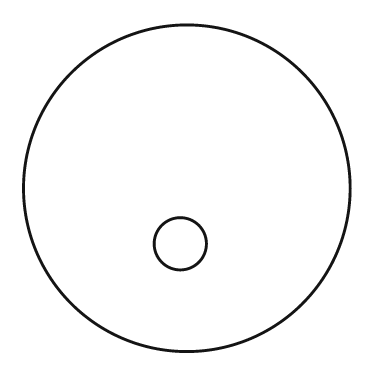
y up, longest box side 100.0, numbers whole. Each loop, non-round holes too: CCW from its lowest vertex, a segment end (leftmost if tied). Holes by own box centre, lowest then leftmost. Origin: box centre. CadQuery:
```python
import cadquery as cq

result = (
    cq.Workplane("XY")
    .moveTo(0.0, 0.0)
    .circle(50.0)
    .moveTo(-2.0, -17.0)
    .circle(8.0)
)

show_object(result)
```